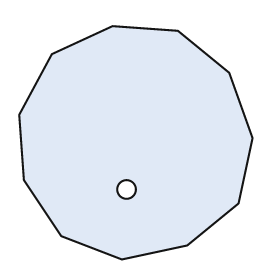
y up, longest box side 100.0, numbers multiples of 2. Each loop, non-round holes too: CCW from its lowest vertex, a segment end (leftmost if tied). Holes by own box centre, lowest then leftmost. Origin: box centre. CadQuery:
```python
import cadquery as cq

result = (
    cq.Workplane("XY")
    .moveTo(-6.0, -50.0)
    .lineTo(22.0, -44.0)
    .lineTo(44.0, -26.0)
    .lineTo(50.0, 2.0)
    .lineTo(40.0, 30.0)
    .lineTo(18.0, 48.0)
    .lineTo(-10.0, 50.0)
    .lineTo(-36.0, 38.0)
    .lineTo(-50.0, 12.0)
    .lineTo(-48.0, -16.0)
    .lineTo(-32.0, -40.0)
    .close()
    .moveTo(-4.0, -20.0)
    .circle(4.0)
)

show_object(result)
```